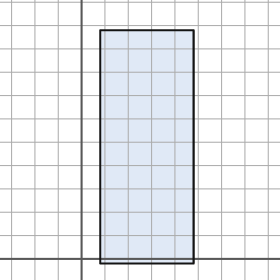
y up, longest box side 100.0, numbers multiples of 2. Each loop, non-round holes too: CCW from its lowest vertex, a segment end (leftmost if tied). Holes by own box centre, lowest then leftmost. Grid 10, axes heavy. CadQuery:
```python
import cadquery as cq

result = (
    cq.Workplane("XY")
    .moveTo(8.0, -2.0)
    .lineTo(48.0, -2.0)
    .lineTo(48.0, 98.0)
    .lineTo(8.0, 98.0)
    .close()
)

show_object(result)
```